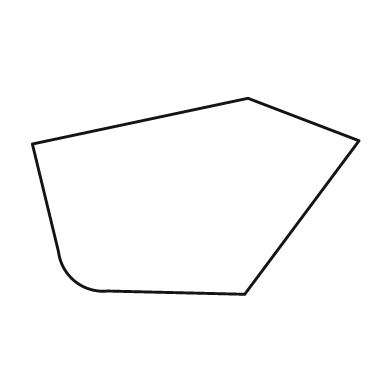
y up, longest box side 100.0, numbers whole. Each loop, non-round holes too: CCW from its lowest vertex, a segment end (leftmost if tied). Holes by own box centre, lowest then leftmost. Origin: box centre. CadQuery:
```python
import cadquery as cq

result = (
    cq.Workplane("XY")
    .moveTo(15.0, -30.0)
    .lineTo(50.0, 17.0)
    .lineTo(16.0, 30.0)
    .lineTo(-50.0, 16.0)
    .lineTo(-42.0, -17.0)
    .threePointArc((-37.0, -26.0), (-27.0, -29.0))
    .close()
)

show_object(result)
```